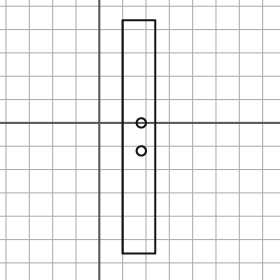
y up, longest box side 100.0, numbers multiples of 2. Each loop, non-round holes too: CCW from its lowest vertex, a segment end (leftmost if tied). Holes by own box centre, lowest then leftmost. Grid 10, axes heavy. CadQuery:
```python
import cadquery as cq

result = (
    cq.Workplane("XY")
    .moveTo(10.0, -56.0)
    .lineTo(24.0, -56.0)
    .lineTo(24.0, 44.0)
    .lineTo(10.0, 44.0)
    .close()
    .moveTo(18.0, -12.0)
    .circle(2.0)
    .moveTo(18.0, 0.0)
    .circle(2.0)
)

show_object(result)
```